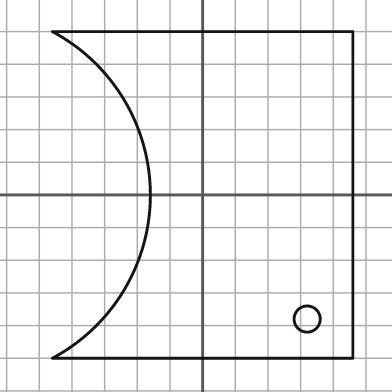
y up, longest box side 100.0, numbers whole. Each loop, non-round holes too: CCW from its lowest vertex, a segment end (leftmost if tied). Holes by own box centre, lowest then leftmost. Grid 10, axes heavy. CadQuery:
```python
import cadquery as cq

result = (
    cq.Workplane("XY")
    .moveTo(-46.0, -50.0)
    .lineTo(46.0, -50.0)
    .lineTo(46.0, 50.0)
    .lineTo(-46.0, 50.0)
    .threePointArc((-16.0, 0.0), (-46.0, -50.0))
    .close()
    .moveTo(32.0, -38.0)
    .circle(4.0)
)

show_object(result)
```